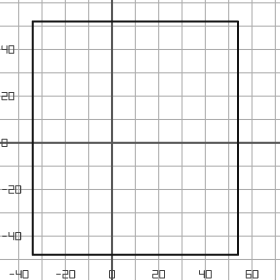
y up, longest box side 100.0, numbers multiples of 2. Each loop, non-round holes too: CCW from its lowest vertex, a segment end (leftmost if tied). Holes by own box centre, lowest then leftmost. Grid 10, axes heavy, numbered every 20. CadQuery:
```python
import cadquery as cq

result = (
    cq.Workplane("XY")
    .moveTo(-34.0, -48.0)
    .lineTo(54.0, -48.0)
    .lineTo(54.0, 52.0)
    .lineTo(-34.0, 52.0)
    .close()
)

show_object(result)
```